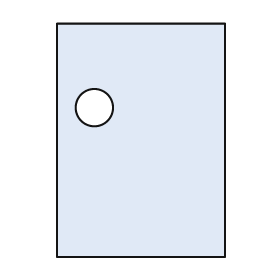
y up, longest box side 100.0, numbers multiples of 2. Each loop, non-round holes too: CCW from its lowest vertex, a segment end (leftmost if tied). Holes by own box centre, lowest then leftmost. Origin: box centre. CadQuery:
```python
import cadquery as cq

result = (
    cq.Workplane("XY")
    .moveTo(-36.0, -50.0)
    .lineTo(36.0, -50.0)
    .lineTo(36.0, 50.0)
    .lineTo(-36.0, 50.0)
    .close()
    .moveTo(-20.0, 14.0)
    .circle(8.0)
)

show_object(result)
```